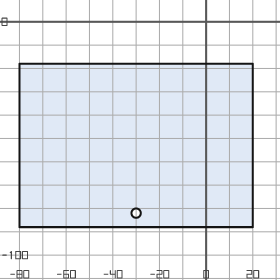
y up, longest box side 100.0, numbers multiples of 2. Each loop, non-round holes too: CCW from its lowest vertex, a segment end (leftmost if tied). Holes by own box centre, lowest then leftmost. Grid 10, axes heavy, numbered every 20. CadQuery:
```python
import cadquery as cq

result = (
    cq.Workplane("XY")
    .moveTo(-80.0, -88.0)
    .lineTo(20.0, -88.0)
    .lineTo(20.0, -18.0)
    .lineTo(-80.0, -18.0)
    .close()
    .moveTo(-30.0, -82.0)
    .circle(2.0)
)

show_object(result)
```